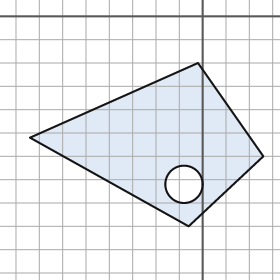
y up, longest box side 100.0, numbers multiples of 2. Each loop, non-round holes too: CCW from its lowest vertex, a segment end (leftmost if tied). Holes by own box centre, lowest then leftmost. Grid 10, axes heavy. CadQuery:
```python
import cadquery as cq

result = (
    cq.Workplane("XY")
    .moveTo(-6.0, -90.0)
    .lineTo(26.0, -60.0)
    .lineTo(-2.0, -20.0)
    .lineTo(-74.0, -52.0)
    .close()
    .moveTo(-8.0, -72.0)
    .circle(8.0)
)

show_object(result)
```